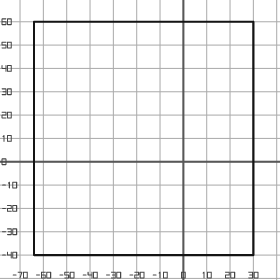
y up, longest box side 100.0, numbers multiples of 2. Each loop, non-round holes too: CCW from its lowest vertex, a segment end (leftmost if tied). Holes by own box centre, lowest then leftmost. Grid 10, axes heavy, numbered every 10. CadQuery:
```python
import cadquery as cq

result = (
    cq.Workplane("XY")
    .moveTo(-64.0, -40.0)
    .lineTo(30.0, -40.0)
    .lineTo(30.0, 60.0)
    .lineTo(-64.0, 60.0)
    .close()
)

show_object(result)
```